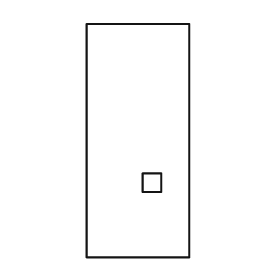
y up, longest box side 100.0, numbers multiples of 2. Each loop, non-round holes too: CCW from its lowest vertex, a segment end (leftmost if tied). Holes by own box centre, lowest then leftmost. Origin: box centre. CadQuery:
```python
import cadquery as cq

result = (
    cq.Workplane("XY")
    .moveTo(-22.0, -50.0)
    .lineTo(22.0, -50.0)
    .lineTo(22.0, 50.0)
    .lineTo(-22.0, 50.0)
    .close()
    .moveTo(2.0, -22.0)
    .lineTo(10.0, -22.0)
    .lineTo(10.0, -14.0)
    .lineTo(2.0, -14.0)
    .close()
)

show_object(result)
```